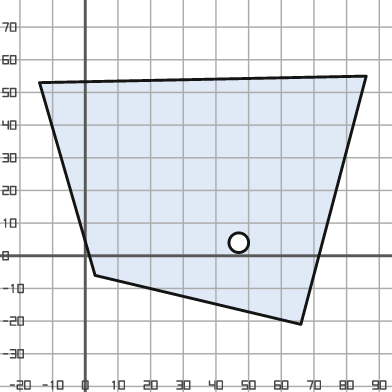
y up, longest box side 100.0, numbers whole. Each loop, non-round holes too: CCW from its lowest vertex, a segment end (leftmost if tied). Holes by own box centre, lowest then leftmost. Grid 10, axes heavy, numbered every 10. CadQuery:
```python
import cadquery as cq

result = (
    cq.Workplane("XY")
    .moveTo(66.0, -21.0)
    .lineTo(86.0, 55.0)
    .lineTo(-14.0, 53.0)
    .lineTo(3.0, -6.0)
    .close()
    .moveTo(47.0, 4.0)
    .circle(3.0)
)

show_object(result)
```